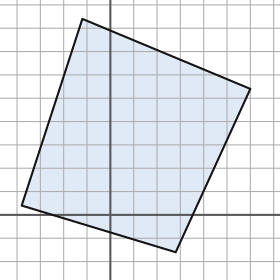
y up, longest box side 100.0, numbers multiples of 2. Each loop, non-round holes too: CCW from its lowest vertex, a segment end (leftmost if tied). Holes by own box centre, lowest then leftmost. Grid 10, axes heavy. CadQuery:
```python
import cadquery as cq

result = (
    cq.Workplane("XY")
    .moveTo(28.0, -16.0)
    .lineTo(60.0, 54.0)
    .lineTo(-12.0, 84.0)
    .lineTo(-38.0, 4.0)
    .close()
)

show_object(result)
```